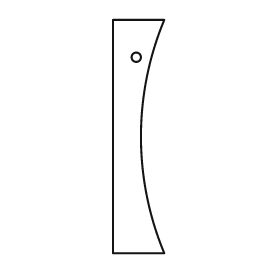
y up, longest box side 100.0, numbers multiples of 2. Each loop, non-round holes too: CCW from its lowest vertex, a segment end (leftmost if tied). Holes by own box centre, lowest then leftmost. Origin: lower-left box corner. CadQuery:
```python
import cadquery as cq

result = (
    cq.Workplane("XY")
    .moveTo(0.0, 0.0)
    .lineTo(22.0, 0.0)
    .threePointArc((12.0, 50.0), (22.0, 100.0))
    .lineTo(0.0, 100.0)
    .close()
    .moveTo(10.0, 84.0)
    .circle(2.0)
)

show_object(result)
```